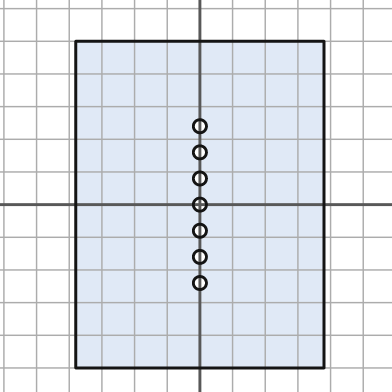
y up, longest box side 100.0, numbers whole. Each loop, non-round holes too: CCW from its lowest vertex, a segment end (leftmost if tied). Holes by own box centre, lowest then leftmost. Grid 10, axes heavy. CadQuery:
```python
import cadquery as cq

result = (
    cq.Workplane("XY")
    .moveTo(-38.0, -50.0)
    .lineTo(38.0, -50.0)
    .lineTo(38.0, 50.0)
    .lineTo(-38.0, 50.0)
    .close()
    .moveTo(0.0, -24.0)
    .circle(2.0)
    .moveTo(0.0, -16.0)
    .circle(2.0)
    .moveTo(0.0, -8.0)
    .circle(2.0)
    .moveTo(0.0, 0.0)
    .circle(2.0)
    .moveTo(0.0, 8.0)
    .circle(2.0)
    .moveTo(0.0, 16.0)
    .circle(2.0)
    .moveTo(0.0, 24.0)
    .circle(2.0)
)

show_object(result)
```